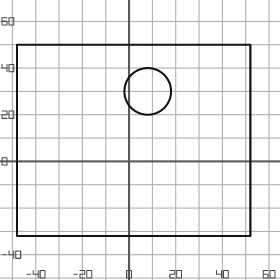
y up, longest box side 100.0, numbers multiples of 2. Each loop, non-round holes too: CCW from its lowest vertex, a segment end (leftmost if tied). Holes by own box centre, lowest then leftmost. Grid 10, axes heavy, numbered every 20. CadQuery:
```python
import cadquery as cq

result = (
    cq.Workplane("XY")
    .moveTo(-48.0, -32.0)
    .lineTo(52.0, -32.0)
    .lineTo(52.0, 50.0)
    .lineTo(-48.0, 50.0)
    .close()
    .moveTo(8.0, 30.0)
    .circle(10.0)
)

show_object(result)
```